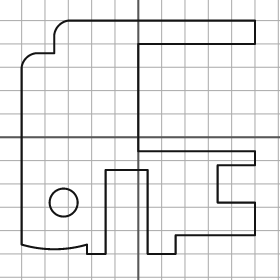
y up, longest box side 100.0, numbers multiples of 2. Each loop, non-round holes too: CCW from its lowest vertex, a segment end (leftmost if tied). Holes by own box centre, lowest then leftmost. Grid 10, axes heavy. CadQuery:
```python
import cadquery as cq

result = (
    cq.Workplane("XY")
    .moveTo(-22.0, -50.0)
    .lineTo(-14.0, -50.0)
    .lineTo(-14.0, -14.0)
    .lineTo(4.0, -14.0)
    .lineTo(4.0, -50.0)
    .lineTo(16.0, -50.0)
    .lineTo(16.0, -42.0)
    .lineTo(50.0, -42.0)
    .lineTo(50.0, -28.0)
    .lineTo(34.0, -28.0)
    .lineTo(34.0, -12.0)
    .lineTo(50.0, -12.0)
    .lineTo(50.0, -6.0)
    .lineTo(0.0, -6.0)
    .lineTo(0.0, 40.0)
    .lineTo(50.0, 40.0)
    .lineTo(50.0, 50.0)
    .lineTo(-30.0, 50.0)
    .threePointArc((-34.0, 48.0), (-36.0, 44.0))
    .lineTo(-36.0, 36.0)
    .lineTo(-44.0, 36.0)
    .threePointArc((-48.0, 34.0), (-50.0, 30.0))
    .lineTo(-50.0, -46.0)
    .threePointArc((-36.0, -48.0), (-22.0, -46.0))
    .close()
    .moveTo(-32.0, -28.0)
    .circle(6.0)
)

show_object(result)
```